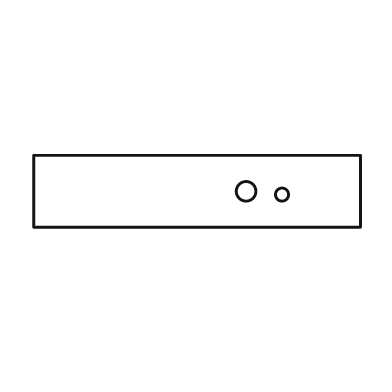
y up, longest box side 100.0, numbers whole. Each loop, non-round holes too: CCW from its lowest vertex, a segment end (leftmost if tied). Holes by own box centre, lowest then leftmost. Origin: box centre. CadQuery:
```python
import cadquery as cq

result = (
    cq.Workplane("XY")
    .moveTo(-50.0, -11.0)
    .lineTo(50.0, -11.0)
    .lineTo(50.0, 11.0)
    .lineTo(-50.0, 11.0)
    .close()
    .moveTo(26.0, -1.0)
    .circle(2.0)
    .moveTo(15.0, 0.0)
    .circle(3.0)
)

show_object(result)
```